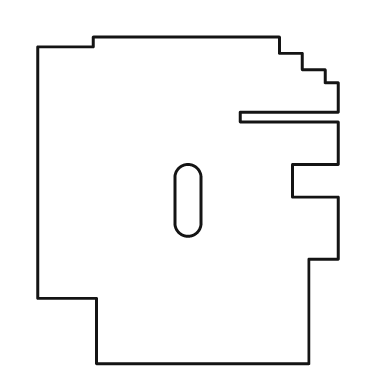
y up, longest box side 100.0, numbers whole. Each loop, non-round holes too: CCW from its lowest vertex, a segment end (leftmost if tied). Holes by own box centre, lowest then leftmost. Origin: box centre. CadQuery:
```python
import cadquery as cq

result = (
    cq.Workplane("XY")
    .moveTo(-28.0, -50.0)
    .lineTo(37.0, -50.0)
    .lineTo(37.0, -18.0)
    .lineTo(46.0, -18.0)
    .lineTo(46.0, 1.0)
    .lineTo(32.0, 1.0)
    .lineTo(32.0, 11.0)
    .lineTo(46.0, 11.0)
    .lineTo(46.0, 24.0)
    .lineTo(16.0, 24.0)
    .lineTo(16.0, 27.0)
    .lineTo(46.0, 27.0)
    .lineTo(46.0, 36.0)
    .lineTo(42.0, 36.0)
    .lineTo(42.0, 40.0)
    .lineTo(35.0, 40.0)
    .lineTo(35.0, 45.0)
    .lineTo(28.0, 45.0)
    .lineTo(28.0, 50.0)
    .lineTo(-29.0, 50.0)
    .lineTo(-29.0, 47.0)
    .lineTo(-46.0, 47.0)
    .lineTo(-46.0, -30.0)
    .lineTo(-28.0, -30.0)
    .close()
    .moveTo(-4.0, -7.0)
    .threePointArc((0.0, -11.0), (4.0, -7.0))
    .lineTo(4.0, 7.0)
    .threePointArc((0.0, 11.0), (-4.0, 7.0))
    .close()
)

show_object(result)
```